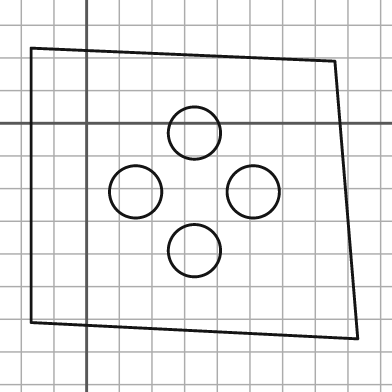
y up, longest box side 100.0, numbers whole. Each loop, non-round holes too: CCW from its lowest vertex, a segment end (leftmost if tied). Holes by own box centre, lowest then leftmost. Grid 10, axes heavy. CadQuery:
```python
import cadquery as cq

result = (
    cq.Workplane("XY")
    .moveTo(83.0, -66.0)
    .lineTo(76.0, 19.0)
    .lineTo(-17.0, 23.0)
    .lineTo(-17.0, -61.0)
    .close()
    .moveTo(33.0, -39.0)
    .circle(8.0)
    .moveTo(15.0, -21.0)
    .circle(8.0)
    .moveTo(51.0, -21.0)
    .circle(8.0)
    .moveTo(33.0, -3.0)
    .circle(8.0)
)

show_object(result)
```